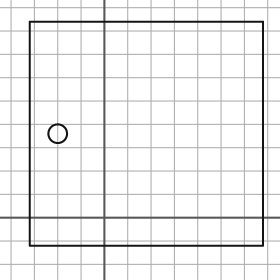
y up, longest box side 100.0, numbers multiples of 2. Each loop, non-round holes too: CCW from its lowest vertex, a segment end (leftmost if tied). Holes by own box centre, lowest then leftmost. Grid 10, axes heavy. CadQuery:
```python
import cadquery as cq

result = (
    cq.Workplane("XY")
    .moveTo(-32.0, -12.0)
    .lineTo(68.0, -12.0)
    .lineTo(68.0, 84.0)
    .lineTo(-32.0, 84.0)
    .close()
    .moveTo(-20.0, 36.0)
    .circle(4.0)
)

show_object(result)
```